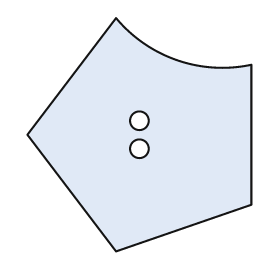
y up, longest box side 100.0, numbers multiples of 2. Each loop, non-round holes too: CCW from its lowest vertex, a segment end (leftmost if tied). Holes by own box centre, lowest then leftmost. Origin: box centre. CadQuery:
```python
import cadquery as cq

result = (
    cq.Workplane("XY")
    .moveTo(-10.0, -50.0)
    .lineTo(48.0, -30.0)
    .lineTo(48.0, 30.0)
    .threePointArc((16.0, 32.0), (-10.0, 50.0))
    .lineTo(-48.0, 0.0)
    .close()
    .moveTo(0.0, -6.0)
    .circle(4.0)
    .moveTo(0.0, 6.0)
    .circle(4.0)
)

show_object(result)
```